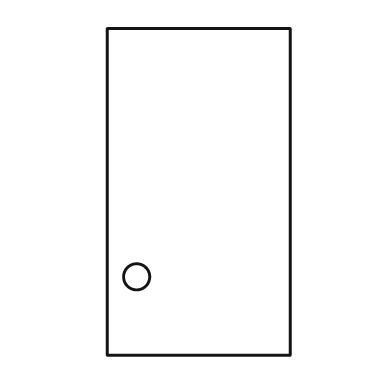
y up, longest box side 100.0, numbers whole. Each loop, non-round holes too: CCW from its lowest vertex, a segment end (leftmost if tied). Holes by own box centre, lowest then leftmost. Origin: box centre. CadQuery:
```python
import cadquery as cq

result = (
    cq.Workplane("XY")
    .moveTo(-28.0, -50.0)
    .lineTo(28.0, -50.0)
    .lineTo(28.0, 50.0)
    .lineTo(-28.0, 50.0)
    .close()
    .moveTo(-19.0, -26.0)
    .circle(4.0)
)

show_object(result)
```